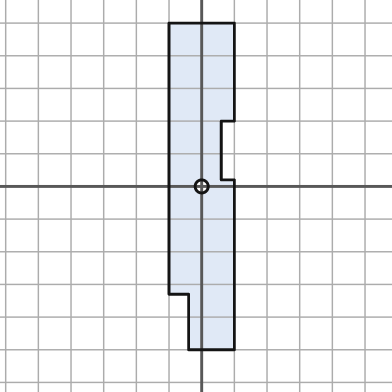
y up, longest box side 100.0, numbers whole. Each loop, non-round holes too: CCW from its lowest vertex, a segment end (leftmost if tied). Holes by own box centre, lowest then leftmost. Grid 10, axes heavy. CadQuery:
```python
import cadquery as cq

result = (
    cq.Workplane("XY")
    .moveTo(-4.0, -50.0)
    .lineTo(10.0, -50.0)
    .lineTo(10.0, 2.0)
    .lineTo(6.0, 2.0)
    .lineTo(6.0, 20.0)
    .lineTo(10.0, 20.0)
    .lineTo(10.0, 50.0)
    .lineTo(-10.0, 50.0)
    .lineTo(-10.0, -33.0)
    .lineTo(-4.0, -33.0)
    .close()
    .moveTo(0.0, 0.0)
    .circle(2.0)
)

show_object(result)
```